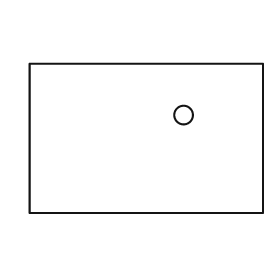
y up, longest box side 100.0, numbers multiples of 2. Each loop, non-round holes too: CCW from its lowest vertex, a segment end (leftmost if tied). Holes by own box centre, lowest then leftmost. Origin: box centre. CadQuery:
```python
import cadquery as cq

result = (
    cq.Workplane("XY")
    .moveTo(-50.0, -32.0)
    .lineTo(50.0, -32.0)
    .lineTo(50.0, 32.0)
    .lineTo(-50.0, 32.0)
    .close()
    .moveTo(16.0, 10.0)
    .circle(4.0)
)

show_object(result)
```